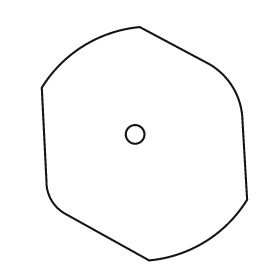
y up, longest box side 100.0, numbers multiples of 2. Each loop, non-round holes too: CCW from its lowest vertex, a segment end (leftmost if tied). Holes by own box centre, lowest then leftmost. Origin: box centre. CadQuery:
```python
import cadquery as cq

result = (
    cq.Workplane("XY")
    .moveTo(2.0, -50.0)
    .threePointArc((26.0, -42.0), (44.0, -24.0))
    .lineTo(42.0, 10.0)
    .threePointArc((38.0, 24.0), (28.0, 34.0))
    .lineTo(-2.0, 50.0)
    .threePointArc((-26.0, 42.0), (-44.0, 24.0))
    .lineTo(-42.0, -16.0)
    .threePointArc((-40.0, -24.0), (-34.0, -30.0))
    .close()
    .moveTo(-4.0, 4.0)
    .circle(4.0)
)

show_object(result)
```